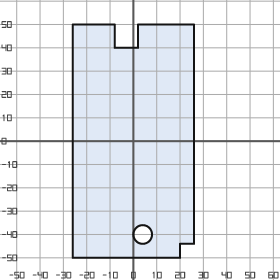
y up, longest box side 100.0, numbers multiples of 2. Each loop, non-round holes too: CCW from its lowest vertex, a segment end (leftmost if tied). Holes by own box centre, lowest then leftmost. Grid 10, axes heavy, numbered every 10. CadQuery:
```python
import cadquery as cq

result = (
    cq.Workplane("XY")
    .moveTo(-26.0, -50.0)
    .lineTo(20.0, -50.0)
    .lineTo(20.0, -44.0)
    .lineTo(26.0, -44.0)
    .lineTo(26.0, 50.0)
    .lineTo(2.0, 50.0)
    .lineTo(2.0, 40.0)
    .lineTo(-8.0, 40.0)
    .lineTo(-8.0, 50.0)
    .lineTo(-26.0, 50.0)
    .close()
    .moveTo(4.0, -40.0)
    .circle(4.0)
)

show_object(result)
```